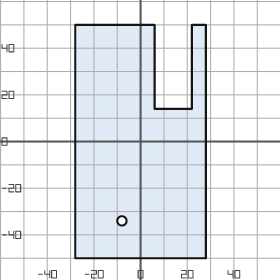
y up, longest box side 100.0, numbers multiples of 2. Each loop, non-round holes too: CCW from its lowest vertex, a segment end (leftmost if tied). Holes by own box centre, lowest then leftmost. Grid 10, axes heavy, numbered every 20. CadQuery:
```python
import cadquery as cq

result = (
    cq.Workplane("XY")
    .moveTo(-28.0, -50.0)
    .lineTo(28.0, -50.0)
    .lineTo(28.0, 50.0)
    .lineTo(22.0, 50.0)
    .lineTo(22.0, 14.0)
    .lineTo(6.0, 14.0)
    .lineTo(6.0, 50.0)
    .lineTo(-28.0, 50.0)
    .close()
    .moveTo(-8.0, -34.0)
    .circle(2.0)
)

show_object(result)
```